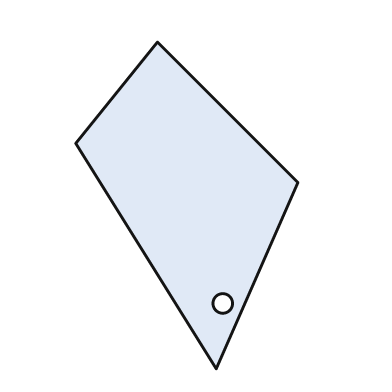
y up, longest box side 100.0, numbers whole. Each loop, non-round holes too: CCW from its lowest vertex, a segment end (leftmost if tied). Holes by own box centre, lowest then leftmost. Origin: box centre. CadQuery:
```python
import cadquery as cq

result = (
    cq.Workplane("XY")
    .moveTo(9.0, -50.0)
    .lineTo(34.0, 7.0)
    .lineTo(-9.0, 50.0)
    .lineTo(-34.0, 19.0)
    .close()
    .moveTo(11.0, -30.0)
    .circle(3.0)
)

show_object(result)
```